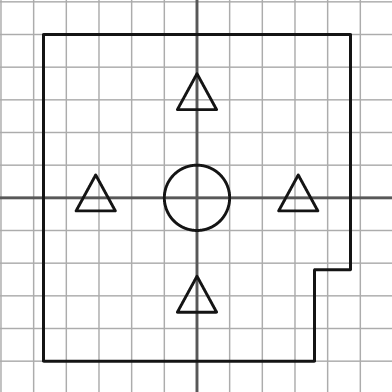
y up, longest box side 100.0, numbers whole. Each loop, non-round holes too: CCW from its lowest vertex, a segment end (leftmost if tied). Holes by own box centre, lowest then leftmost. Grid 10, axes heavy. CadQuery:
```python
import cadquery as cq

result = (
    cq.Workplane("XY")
    .moveTo(-47.0, -50.0)
    .lineTo(36.0, -50.0)
    .lineTo(36.0, -22.0)
    .lineTo(47.0, -22.0)
    .lineTo(47.0, 50.0)
    .lineTo(-47.0, 50.0)
    .close()
    .moveTo(-6.0, -35.0)
    .lineTo(6.0, -35.0)
    .lineTo(0.0, -24.0)
    .close()
    .moveTo(0.0, 0.0)
    .circle(10.0)
    .moveTo(-37.0, -4.0)
    .lineTo(-25.0, -4.0)
    .lineTo(-31.0, 7.0)
    .close()
    .moveTo(25.0, -4.0)
    .lineTo(37.0, -4.0)
    .lineTo(31.0, 7.0)
    .close()
    .moveTo(-6.0, 27.0)
    .lineTo(6.0, 27.0)
    .lineTo(0.0, 38.0)
    .close()
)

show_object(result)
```